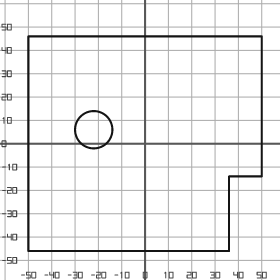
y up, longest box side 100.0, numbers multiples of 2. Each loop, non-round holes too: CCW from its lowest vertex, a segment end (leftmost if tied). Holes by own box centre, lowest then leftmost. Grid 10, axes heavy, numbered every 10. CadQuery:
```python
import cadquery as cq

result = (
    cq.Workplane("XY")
    .moveTo(-50.0, -46.0)
    .lineTo(36.0, -46.0)
    .lineTo(36.0, -14.0)
    .lineTo(50.0, -14.0)
    .lineTo(50.0, 46.0)
    .lineTo(-50.0, 46.0)
    .close()
    .moveTo(-22.0, 6.0)
    .circle(8.0)
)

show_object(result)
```